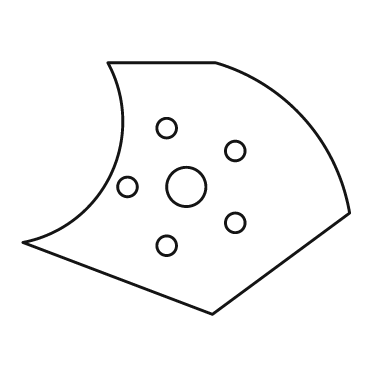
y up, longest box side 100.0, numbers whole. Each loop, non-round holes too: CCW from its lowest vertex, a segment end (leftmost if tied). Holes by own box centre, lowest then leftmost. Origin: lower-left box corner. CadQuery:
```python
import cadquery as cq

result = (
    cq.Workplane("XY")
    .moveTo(58.0, 0.0)
    .lineTo(100.0, 31.0)
    .threePointArc((86.0, 60.0), (59.0, 77.0))
    .lineTo(26.0, 77.0)
    .threePointArc((27.0, 43.0), (0.0, 22.0))
    .close()
    .moveTo(44.0, 21.0)
    .circle(3.0)
    .moveTo(65.0, 28.0)
    .circle(3.0)
    .moveTo(32.0, 39.0)
    .circle(3.0)
    .moveTo(50.0, 39.0)
    .circle(6.0)
    .moveTo(65.0, 50.0)
    .circle(3.0)
    .moveTo(44.0, 57.0)
    .circle(3.0)
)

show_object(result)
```